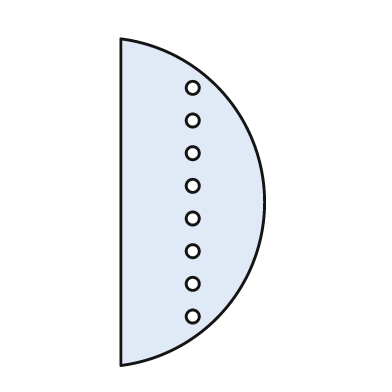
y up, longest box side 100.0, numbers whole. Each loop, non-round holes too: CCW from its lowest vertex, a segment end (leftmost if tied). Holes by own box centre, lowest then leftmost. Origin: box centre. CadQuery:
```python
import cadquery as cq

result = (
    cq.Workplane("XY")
    .moveTo(-22.0, -50.0)
    .threePointArc((22.0, 0.0), (-22.0, 50.0))
    .close()
    .moveTo(0.0, -35.0)
    .circle(2.0)
    .moveTo(0.0, -25.0)
    .circle(2.0)
    .moveTo(0.0, -15.0)
    .circle(2.0)
    .moveTo(0.0, -5.0)
    .circle(2.0)
    .moveTo(0.0, 5.0)
    .circle(2.0)
    .moveTo(0.0, 15.0)
    .circle(2.0)
    .moveTo(0.0, 25.0)
    .circle(2.0)
    .moveTo(0.0, 35.0)
    .circle(2.0)
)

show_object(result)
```